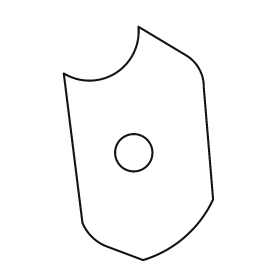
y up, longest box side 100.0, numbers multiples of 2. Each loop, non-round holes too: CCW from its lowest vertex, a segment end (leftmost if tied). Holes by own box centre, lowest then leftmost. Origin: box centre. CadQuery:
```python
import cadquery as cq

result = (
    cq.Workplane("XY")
    .moveTo(2.0, -50.0)
    .threePointArc((20.0, -40.0), (32.0, -24.0))
    .lineTo(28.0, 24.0)
    .threePointArc((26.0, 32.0), (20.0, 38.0))
    .lineTo(0.0, 50.0)
    .threePointArc((-10.0, 30.0), (-32.0, 30.0))
    .lineTo(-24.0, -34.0)
    .threePointArc((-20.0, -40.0), (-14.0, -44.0))
    .close()
    .moveTo(-2.0, -4.0)
    .circle(8.0)
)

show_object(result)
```